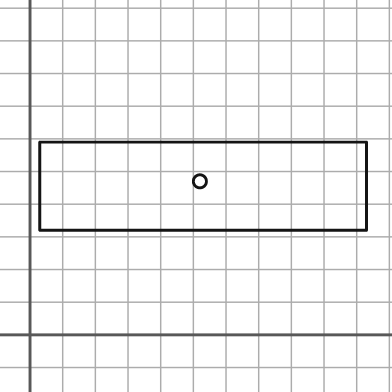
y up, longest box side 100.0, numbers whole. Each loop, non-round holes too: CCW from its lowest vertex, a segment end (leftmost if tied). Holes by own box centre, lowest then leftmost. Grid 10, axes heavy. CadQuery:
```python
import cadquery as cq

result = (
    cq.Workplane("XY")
    .moveTo(3.0, 32.0)
    .lineTo(103.0, 32.0)
    .lineTo(103.0, 59.0)
    .lineTo(3.0, 59.0)
    .close()
    .moveTo(52.0, 47.0)
    .circle(2.0)
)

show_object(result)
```